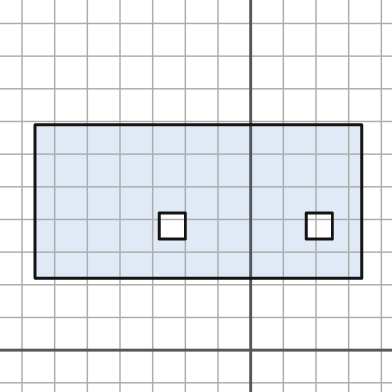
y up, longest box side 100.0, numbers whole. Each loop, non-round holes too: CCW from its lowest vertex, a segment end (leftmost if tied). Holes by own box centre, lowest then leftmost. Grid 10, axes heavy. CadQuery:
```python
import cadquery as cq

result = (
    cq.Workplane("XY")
    .moveTo(-66.0, 22.0)
    .lineTo(34.0, 22.0)
    .lineTo(34.0, 69.0)
    .lineTo(-66.0, 69.0)
    .close()
    .moveTo(-28.0, 34.0)
    .lineTo(-20.0, 34.0)
    .lineTo(-20.0, 42.0)
    .lineTo(-28.0, 42.0)
    .close()
    .moveTo(17.0, 34.0)
    .lineTo(25.0, 34.0)
    .lineTo(25.0, 42.0)
    .lineTo(17.0, 42.0)
    .close()
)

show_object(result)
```